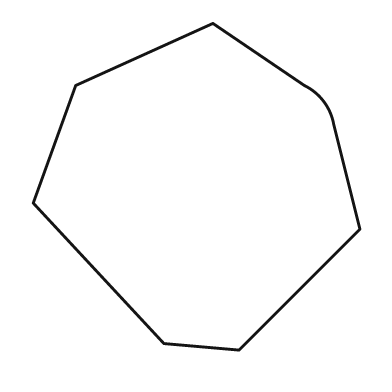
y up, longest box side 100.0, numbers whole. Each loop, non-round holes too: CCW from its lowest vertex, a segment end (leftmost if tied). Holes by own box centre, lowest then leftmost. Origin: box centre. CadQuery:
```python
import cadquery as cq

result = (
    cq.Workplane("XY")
    .moveTo(13.0, -50.0)
    .lineTo(50.0, -13.0)
    .lineTo(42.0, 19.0)
    .threePointArc((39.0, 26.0), (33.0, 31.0))
    .lineTo(5.0, 50.0)
    .lineTo(-37.0, 31.0)
    .lineTo(-50.0, -5.0)
    .lineTo(-10.0, -48.0)
    .close()
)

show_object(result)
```